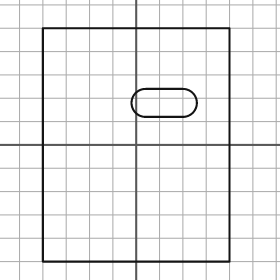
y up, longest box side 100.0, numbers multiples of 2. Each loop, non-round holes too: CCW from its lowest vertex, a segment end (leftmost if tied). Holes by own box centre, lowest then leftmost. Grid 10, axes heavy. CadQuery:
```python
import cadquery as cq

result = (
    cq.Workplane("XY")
    .moveTo(-40.0, -50.0)
    .lineTo(40.0, -50.0)
    .lineTo(40.0, 50.0)
    .lineTo(-40.0, 50.0)
    .close()
    .moveTo(4.0, 12.0)
    .lineTo(20.0, 12.0)
    .threePointArc((26.0, 18.0), (20.0, 24.0))
    .lineTo(4.0, 24.0)
    .threePointArc((-2.0, 18.0), (4.0, 12.0))
    .close()
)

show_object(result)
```